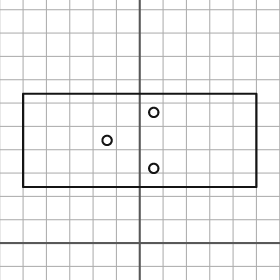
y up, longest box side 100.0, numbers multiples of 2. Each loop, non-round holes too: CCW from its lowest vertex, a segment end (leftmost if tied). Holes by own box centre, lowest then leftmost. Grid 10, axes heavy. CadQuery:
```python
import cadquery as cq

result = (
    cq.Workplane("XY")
    .moveTo(-50.0, 24.0)
    .lineTo(50.0, 24.0)
    .lineTo(50.0, 64.0)
    .lineTo(-50.0, 64.0)
    .close()
    .moveTo(6.0, 32.0)
    .circle(2.0)
    .moveTo(-14.0, 44.0)
    .circle(2.0)
    .moveTo(6.0, 56.0)
    .circle(2.0)
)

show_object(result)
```